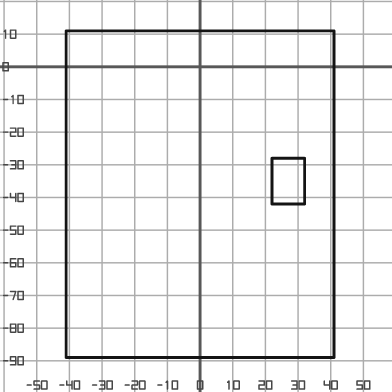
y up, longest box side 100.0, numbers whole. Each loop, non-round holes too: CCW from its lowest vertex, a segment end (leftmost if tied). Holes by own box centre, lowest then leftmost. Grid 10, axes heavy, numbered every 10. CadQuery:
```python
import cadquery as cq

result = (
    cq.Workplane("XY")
    .moveTo(-41.0, -89.0)
    .lineTo(41.0, -89.0)
    .lineTo(41.0, 11.0)
    .lineTo(-41.0, 11.0)
    .close()
    .moveTo(22.0, -42.0)
    .lineTo(32.0, -42.0)
    .lineTo(32.0, -28.0)
    .lineTo(22.0, -28.0)
    .close()
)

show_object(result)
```